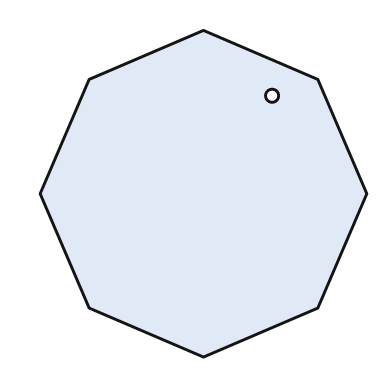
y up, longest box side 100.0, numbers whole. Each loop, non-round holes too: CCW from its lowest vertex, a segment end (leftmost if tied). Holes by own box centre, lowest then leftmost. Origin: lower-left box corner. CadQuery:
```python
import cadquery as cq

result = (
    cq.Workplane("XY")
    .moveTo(50.0, 0.0)
    .lineTo(85.0, 15.0)
    .lineTo(100.0, 50.0)
    .lineTo(85.0, 85.0)
    .lineTo(50.0, 100.0)
    .lineTo(15.0, 85.0)
    .lineTo(0.0, 50.0)
    .lineTo(15.0, 15.0)
    .close()
    .moveTo(71.0, 80.0)
    .circle(2.0)
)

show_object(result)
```